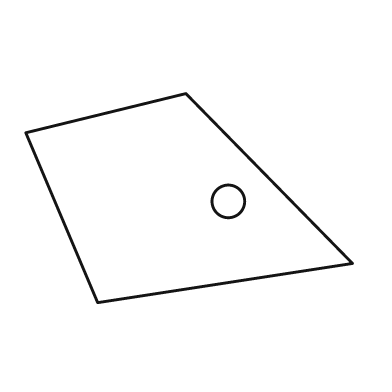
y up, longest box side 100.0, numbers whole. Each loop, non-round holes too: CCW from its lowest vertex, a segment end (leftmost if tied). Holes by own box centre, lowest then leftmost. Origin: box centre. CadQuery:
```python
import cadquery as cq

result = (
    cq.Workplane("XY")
    .moveTo(-28.0, -32.0)
    .lineTo(50.0, -20.0)
    .lineTo(-1.0, 32.0)
    .lineTo(-50.0, 20.0)
    .close()
    .moveTo(12.0, -1.0)
    .circle(5.0)
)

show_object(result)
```